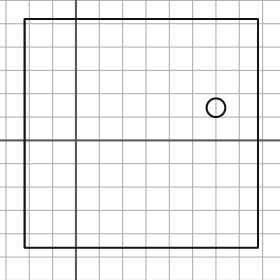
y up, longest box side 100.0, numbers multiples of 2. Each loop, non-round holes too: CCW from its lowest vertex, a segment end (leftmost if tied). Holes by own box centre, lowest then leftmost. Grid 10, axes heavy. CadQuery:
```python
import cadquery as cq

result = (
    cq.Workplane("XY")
    .moveTo(-22.0, -46.0)
    .lineTo(78.0, -46.0)
    .lineTo(78.0, 52.0)
    .lineTo(-22.0, 52.0)
    .close()
    .moveTo(60.0, 14.0)
    .circle(4.0)
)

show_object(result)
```